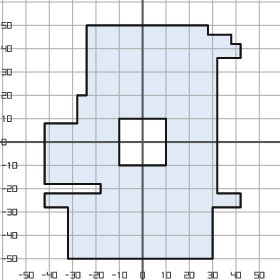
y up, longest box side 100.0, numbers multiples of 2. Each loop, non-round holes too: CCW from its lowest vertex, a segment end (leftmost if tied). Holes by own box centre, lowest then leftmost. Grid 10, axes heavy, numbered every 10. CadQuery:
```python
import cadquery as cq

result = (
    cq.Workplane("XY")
    .moveTo(-32.0, -50.0)
    .lineTo(30.0, -50.0)
    .lineTo(30.0, -28.0)
    .lineTo(42.0, -28.0)
    .lineTo(42.0, -22.0)
    .lineTo(32.0, -22.0)
    .lineTo(32.0, 36.0)
    .lineTo(42.0, 36.0)
    .lineTo(42.0, 42.0)
    .lineTo(38.0, 42.0)
    .lineTo(38.0, 46.0)
    .lineTo(28.0, 46.0)
    .lineTo(28.0, 50.0)
    .lineTo(-24.0, 50.0)
    .lineTo(-24.0, 20.0)
    .lineTo(-28.0, 20.0)
    .lineTo(-28.0, 8.0)
    .lineTo(-42.0, 8.0)
    .lineTo(-42.0, -18.0)
    .lineTo(-18.0, -18.0)
    .lineTo(-18.0, -22.0)
    .lineTo(-42.0, -22.0)
    .lineTo(-42.0, -28.0)
    .lineTo(-32.0, -28.0)
    .close()
    .moveTo(-10.0, -10.0)
    .lineTo(10.0, -10.0)
    .lineTo(10.0, 10.0)
    .lineTo(-10.0, 10.0)
    .close()
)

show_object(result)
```